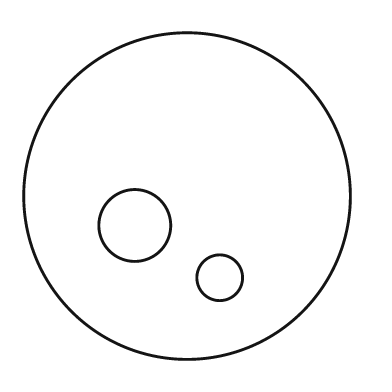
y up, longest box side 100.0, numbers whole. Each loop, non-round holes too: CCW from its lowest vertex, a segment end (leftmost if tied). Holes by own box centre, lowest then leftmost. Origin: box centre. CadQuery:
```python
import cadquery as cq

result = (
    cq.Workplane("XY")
    .moveTo(0.0, 0.0)
    .circle(50.0)
    .moveTo(10.0, -25.0)
    .circle(7.0)
    .moveTo(-16.0, -9.0)
    .circle(11.0)
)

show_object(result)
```